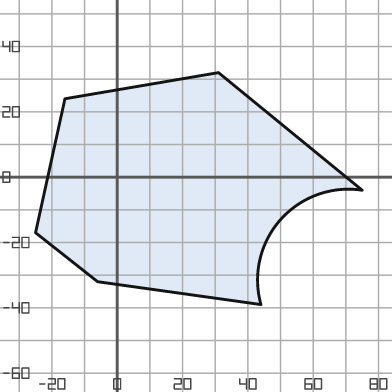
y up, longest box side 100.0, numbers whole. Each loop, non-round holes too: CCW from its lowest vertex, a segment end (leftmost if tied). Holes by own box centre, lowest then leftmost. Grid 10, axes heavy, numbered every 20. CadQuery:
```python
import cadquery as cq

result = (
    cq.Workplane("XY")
    .moveTo(44.0, -39.0)
    .threePointArc((50.0, -13.0), (75.0, -4.0))
    .lineTo(31.0, 32.0)
    .lineTo(-16.0, 24.0)
    .lineTo(-25.0, -17.0)
    .lineTo(-6.0, -32.0)
    .close()
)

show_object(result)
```